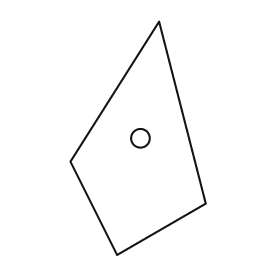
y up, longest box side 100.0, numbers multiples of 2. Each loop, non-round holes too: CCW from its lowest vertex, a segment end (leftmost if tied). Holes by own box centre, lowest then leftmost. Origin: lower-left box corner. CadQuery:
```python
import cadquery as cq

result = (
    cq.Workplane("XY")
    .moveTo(20.0, 0.0)
    .lineTo(58.0, 22.0)
    .lineTo(38.0, 100.0)
    .lineTo(0.0, 40.0)
    .close()
    .moveTo(30.0, 50.0)
    .circle(4.0)
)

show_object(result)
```